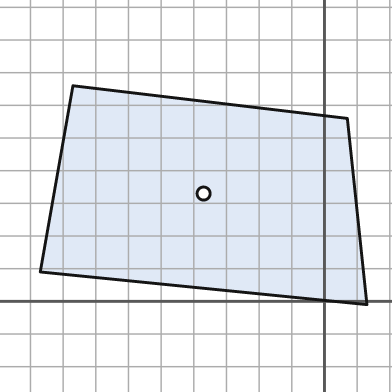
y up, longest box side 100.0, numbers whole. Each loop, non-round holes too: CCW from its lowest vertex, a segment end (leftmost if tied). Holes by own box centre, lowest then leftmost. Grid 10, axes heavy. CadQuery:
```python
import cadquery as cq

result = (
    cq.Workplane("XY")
    .moveTo(13.0, -1.0)
    .lineTo(7.0, 56.0)
    .lineTo(-77.0, 66.0)
    .lineTo(-87.0, 9.0)
    .close()
    .moveTo(-37.0, 33.0)
    .circle(2.0)
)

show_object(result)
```